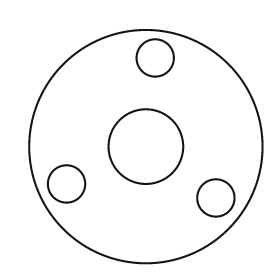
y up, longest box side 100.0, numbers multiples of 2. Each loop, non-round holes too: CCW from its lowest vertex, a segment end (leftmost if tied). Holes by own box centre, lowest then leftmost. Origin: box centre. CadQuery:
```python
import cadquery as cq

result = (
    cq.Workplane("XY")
    .moveTo(0.0, 0.0)
    .circle(50.0)
    .moveTo(30.0, -22.0)
    .circle(8.0)
    .moveTo(-34.0, -16.0)
    .circle(8.0)
    .moveTo(0.0, 0.0)
    .circle(16.0)
    .moveTo(4.0, 38.0)
    .circle(8.0)
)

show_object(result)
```